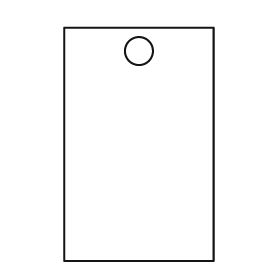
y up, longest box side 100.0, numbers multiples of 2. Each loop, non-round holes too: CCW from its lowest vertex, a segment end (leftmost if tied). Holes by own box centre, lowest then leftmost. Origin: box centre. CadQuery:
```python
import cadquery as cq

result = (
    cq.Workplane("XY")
    .moveTo(-32.0, -50.0)
    .lineTo(32.0, -50.0)
    .lineTo(32.0, 50.0)
    .lineTo(-32.0, 50.0)
    .close()
    .moveTo(0.0, 40.0)
    .circle(6.0)
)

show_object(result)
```